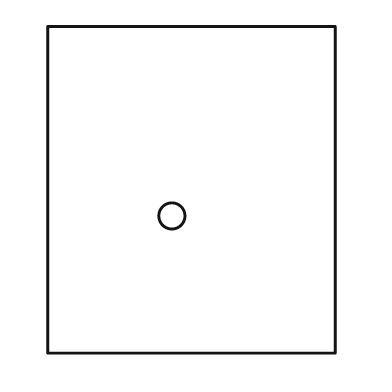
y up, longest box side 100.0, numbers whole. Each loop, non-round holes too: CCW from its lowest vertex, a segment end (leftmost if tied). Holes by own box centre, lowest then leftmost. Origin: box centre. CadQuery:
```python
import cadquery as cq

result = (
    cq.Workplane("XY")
    .moveTo(-44.0, -50.0)
    .lineTo(44.0, -50.0)
    .lineTo(44.0, 50.0)
    .lineTo(-44.0, 50.0)
    .close()
    .moveTo(-6.0, -8.0)
    .circle(4.0)
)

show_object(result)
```